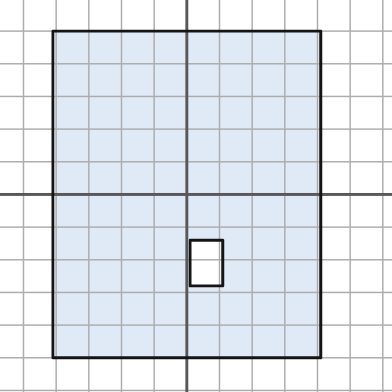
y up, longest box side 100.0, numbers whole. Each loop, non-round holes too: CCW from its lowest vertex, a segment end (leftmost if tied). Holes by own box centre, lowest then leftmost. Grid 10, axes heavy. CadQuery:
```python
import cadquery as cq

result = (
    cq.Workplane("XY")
    .moveTo(-41.0, -50.0)
    .lineTo(41.0, -50.0)
    .lineTo(41.0, 50.0)
    .lineTo(-41.0, 50.0)
    .close()
    .moveTo(1.0, -28.0)
    .lineTo(11.0, -28.0)
    .lineTo(11.0, -14.0)
    .lineTo(1.0, -14.0)
    .close()
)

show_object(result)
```